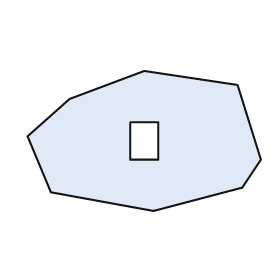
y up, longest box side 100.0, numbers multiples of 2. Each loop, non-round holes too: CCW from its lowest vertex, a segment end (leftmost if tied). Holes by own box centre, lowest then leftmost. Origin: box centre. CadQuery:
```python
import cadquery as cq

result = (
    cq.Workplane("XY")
    .moveTo(4.0, -30.0)
    .lineTo(42.0, -20.0)
    .lineTo(50.0, -8.0)
    .lineTo(40.0, 24.0)
    .lineTo(0.0, 30.0)
    .lineTo(-32.0, 18.0)
    .lineTo(-50.0, 2.0)
    .lineTo(-40.0, -22.0)
    .close()
    .moveTo(-6.0, -8.0)
    .lineTo(6.0, -8.0)
    .lineTo(6.0, 8.0)
    .lineTo(-6.0, 8.0)
    .close()
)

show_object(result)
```